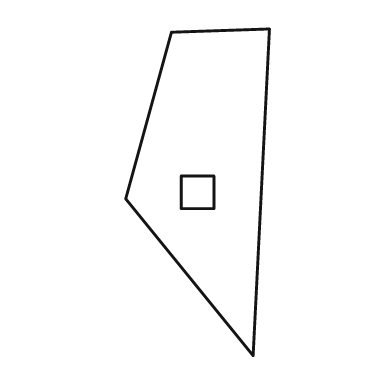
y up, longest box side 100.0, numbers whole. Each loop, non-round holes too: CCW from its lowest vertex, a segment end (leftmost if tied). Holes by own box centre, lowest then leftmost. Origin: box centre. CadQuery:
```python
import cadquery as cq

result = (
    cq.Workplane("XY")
    .moveTo(17.0, -50.0)
    .lineTo(22.0, 50.0)
    .lineTo(-8.0, 49.0)
    .lineTo(-22.0, -2.0)
    .close()
    .moveTo(-5.0, -5.0)
    .lineTo(5.0, -5.0)
    .lineTo(5.0, 5.0)
    .lineTo(-5.0, 5.0)
    .close()
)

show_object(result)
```